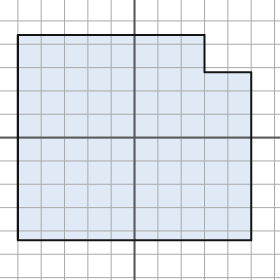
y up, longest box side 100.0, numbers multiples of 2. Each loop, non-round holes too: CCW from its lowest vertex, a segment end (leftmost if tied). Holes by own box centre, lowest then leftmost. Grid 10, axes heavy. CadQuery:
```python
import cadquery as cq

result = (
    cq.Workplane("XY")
    .moveTo(-50.0, -44.0)
    .lineTo(50.0, -44.0)
    .lineTo(50.0, 28.0)
    .lineTo(30.0, 28.0)
    .lineTo(30.0, 44.0)
    .lineTo(-50.0, 44.0)
    .close()
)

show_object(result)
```